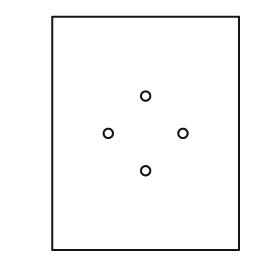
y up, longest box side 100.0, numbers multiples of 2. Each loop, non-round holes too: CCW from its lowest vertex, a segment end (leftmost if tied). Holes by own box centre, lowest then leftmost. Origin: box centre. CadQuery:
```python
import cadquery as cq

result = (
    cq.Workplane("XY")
    .moveTo(-40.0, -50.0)
    .lineTo(40.0, -50.0)
    .lineTo(40.0, 50.0)
    .lineTo(-40.0, 50.0)
    .close()
    .moveTo(0.0, -16.0)
    .circle(2.0)
    .moveTo(-16.0, 0.0)
    .circle(2.0)
    .moveTo(16.0, 0.0)
    .circle(2.0)
    .moveTo(0.0, 16.0)
    .circle(2.0)
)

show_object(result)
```